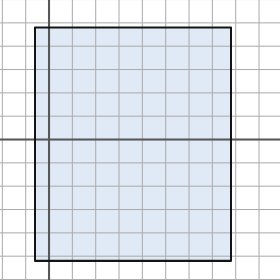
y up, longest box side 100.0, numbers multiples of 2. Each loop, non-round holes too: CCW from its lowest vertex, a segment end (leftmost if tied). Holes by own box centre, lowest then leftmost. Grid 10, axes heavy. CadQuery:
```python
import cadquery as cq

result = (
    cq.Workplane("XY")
    .moveTo(-6.0, -52.0)
    .lineTo(78.0, -52.0)
    .lineTo(78.0, 48.0)
    .lineTo(-6.0, 48.0)
    .close()
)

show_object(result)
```